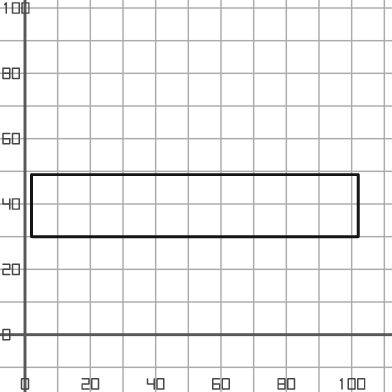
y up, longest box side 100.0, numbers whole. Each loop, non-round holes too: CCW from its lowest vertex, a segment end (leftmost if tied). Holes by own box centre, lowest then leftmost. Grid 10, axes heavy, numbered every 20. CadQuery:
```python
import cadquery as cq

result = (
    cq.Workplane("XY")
    .moveTo(2.0, 30.0)
    .lineTo(102.0, 30.0)
    .lineTo(102.0, 49.0)
    .lineTo(2.0, 49.0)
    .close()
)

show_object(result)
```